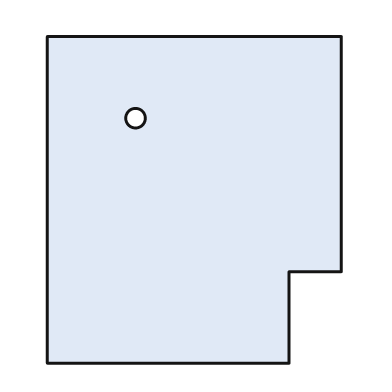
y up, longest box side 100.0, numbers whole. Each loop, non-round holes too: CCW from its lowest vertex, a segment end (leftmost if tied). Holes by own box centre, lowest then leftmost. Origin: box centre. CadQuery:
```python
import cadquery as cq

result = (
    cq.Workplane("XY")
    .moveTo(-45.0, -50.0)
    .lineTo(29.0, -50.0)
    .lineTo(29.0, -22.0)
    .lineTo(45.0, -22.0)
    .lineTo(45.0, 50.0)
    .lineTo(-45.0, 50.0)
    .close()
    .moveTo(-18.0, 25.0)
    .circle(3.0)
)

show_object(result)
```